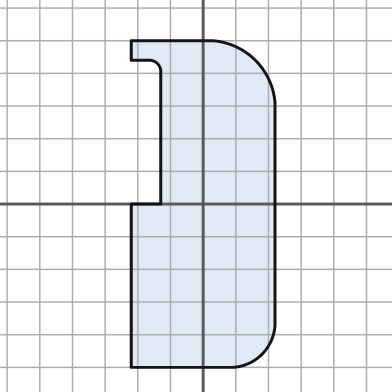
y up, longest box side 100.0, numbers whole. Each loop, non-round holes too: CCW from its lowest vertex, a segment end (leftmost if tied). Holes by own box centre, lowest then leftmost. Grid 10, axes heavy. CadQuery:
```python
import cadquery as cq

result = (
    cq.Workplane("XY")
    .moveTo(-22.0, -50.0)
    .lineTo(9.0, -50.0)
    .threePointArc((18.0, -46.0), (22.0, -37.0))
    .lineTo(22.0, 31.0)
    .threePointArc((16.0, 44.0), (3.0, 50.0))
    .lineTo(-22.0, 50.0)
    .lineTo(-22.0, 44.0)
    .lineTo(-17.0, 44.0)
    .threePointArc((-14.0, 43.0), (-13.0, 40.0))
    .lineTo(-13.0, 0.0)
    .lineTo(-22.0, 0.0)
    .close()
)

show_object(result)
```